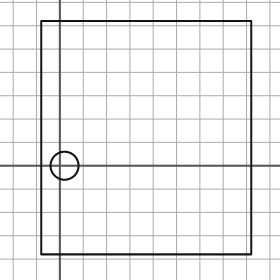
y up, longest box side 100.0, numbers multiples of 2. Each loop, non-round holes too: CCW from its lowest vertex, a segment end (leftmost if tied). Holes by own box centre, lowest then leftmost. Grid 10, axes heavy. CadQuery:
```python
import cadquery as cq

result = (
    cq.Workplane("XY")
    .moveTo(-8.0, -38.0)
    .lineTo(82.0, -38.0)
    .lineTo(82.0, 62.0)
    .lineTo(-8.0, 62.0)
    .close()
    .moveTo(2.0, 0.0)
    .circle(6.0)
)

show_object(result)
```